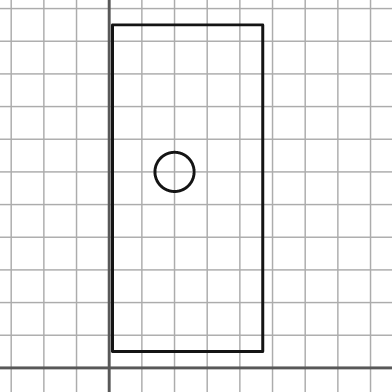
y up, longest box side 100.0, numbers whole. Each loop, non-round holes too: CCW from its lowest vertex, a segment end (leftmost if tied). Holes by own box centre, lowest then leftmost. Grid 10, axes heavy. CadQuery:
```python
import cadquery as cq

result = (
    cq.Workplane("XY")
    .moveTo(1.0, 5.0)
    .lineTo(47.0, 5.0)
    .lineTo(47.0, 105.0)
    .lineTo(1.0, 105.0)
    .close()
    .moveTo(20.0, 60.0)
    .circle(6.0)
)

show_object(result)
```